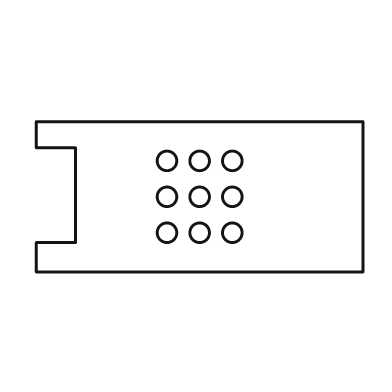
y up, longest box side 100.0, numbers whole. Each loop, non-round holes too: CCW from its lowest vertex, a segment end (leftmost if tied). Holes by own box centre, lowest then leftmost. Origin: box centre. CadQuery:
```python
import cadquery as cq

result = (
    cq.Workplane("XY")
    .moveTo(-50.0, -23.0)
    .lineTo(50.0, -23.0)
    .lineTo(50.0, 23.0)
    .lineTo(-50.0, 23.0)
    .lineTo(-50.0, 15.0)
    .lineTo(-38.0, 15.0)
    .lineTo(-38.0, -14.0)
    .lineTo(-50.0, -14.0)
    .close()
    .moveTo(-10.0, -11.0)
    .circle(3.0)
    .moveTo(0.0, -11.0)
    .circle(3.0)
    .moveTo(10.0, -11.0)
    .circle(3.0)
    .moveTo(-10.0, 0.0)
    .circle(3.0)
    .moveTo(0.0, 0.0)
    .circle(3.0)
    .moveTo(10.0, 0.0)
    .circle(3.0)
    .moveTo(-10.0, 11.0)
    .circle(3.0)
    .moveTo(0.0, 11.0)
    .circle(3.0)
    .moveTo(10.0, 11.0)
    .circle(3.0)
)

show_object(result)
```